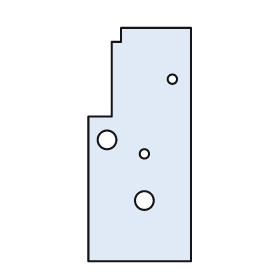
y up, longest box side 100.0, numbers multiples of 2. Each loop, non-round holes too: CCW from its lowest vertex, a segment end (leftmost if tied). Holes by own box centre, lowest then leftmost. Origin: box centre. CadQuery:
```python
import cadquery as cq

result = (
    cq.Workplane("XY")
    .moveTo(-22.0, -50.0)
    .lineTo(22.0, -50.0)
    .lineTo(22.0, 50.0)
    .lineTo(-8.0, 50.0)
    .lineTo(-8.0, 44.0)
    .lineTo(-12.0, 44.0)
    .lineTo(-12.0, 12.0)
    .lineTo(-22.0, 12.0)
    .close()
    .moveTo(2.0, -24.0)
    .circle(4.0)
    .moveTo(2.0, -4.0)
    .circle(2.0)
    .moveTo(-14.0, 2.0)
    .circle(4.0)
    .moveTo(14.0, 28.0)
    .circle(2.0)
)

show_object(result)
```